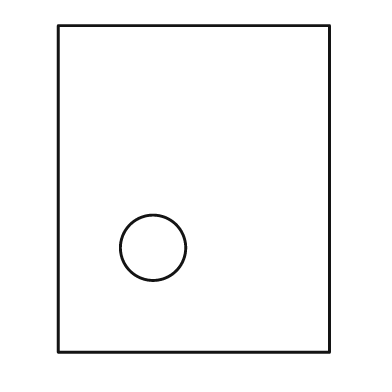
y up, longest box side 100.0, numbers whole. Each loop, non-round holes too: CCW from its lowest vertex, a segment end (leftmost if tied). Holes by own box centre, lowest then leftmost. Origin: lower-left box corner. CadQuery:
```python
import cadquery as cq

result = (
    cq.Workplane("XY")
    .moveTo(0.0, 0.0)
    .lineTo(83.0, 0.0)
    .lineTo(83.0, 100.0)
    .lineTo(0.0, 100.0)
    .close()
    .moveTo(29.0, 32.0)
    .circle(10.0)
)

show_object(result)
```